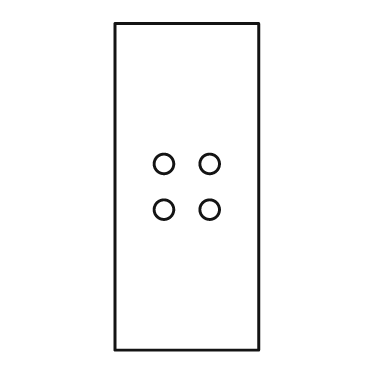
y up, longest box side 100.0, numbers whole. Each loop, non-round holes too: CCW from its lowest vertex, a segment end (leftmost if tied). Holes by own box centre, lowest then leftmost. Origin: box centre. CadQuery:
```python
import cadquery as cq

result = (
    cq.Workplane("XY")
    .moveTo(-22.0, -50.0)
    .lineTo(22.0, -50.0)
    .lineTo(22.0, 50.0)
    .lineTo(-22.0, 50.0)
    .close()
    .moveTo(-7.0, -7.0)
    .circle(3.0)
    .moveTo(7.0, -7.0)
    .circle(3.0)
    .moveTo(-7.0, 7.0)
    .circle(3.0)
    .moveTo(7.0, 7.0)
    .circle(3.0)
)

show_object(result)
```